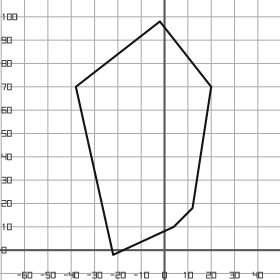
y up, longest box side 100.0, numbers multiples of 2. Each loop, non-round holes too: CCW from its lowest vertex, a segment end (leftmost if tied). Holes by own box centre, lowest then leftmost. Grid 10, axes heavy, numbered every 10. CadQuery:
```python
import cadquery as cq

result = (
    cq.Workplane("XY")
    .moveTo(-22.0, -2.0)
    .lineTo(4.0, 10.0)
    .lineTo(12.0, 18.0)
    .lineTo(20.0, 70.0)
    .lineTo(-2.0, 98.0)
    .lineTo(-38.0, 70.0)
    .close()
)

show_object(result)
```